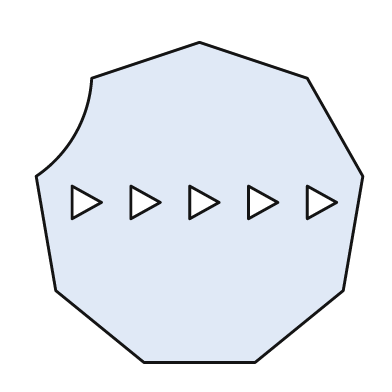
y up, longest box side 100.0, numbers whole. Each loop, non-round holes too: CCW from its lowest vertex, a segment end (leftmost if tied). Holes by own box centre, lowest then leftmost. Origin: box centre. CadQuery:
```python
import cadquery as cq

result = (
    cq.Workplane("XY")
    .moveTo(-17.0, -49.0)
    .lineTo(17.0, -49.0)
    .lineTo(44.0, -27.0)
    .lineTo(50.0, 8.0)
    .lineTo(33.0, 38.0)
    .lineTo(0.0, 49.0)
    .lineTo(-33.0, 38.0)
    .threePointArc((-38.0, 21.0), (-50.0, 8.0))
    .lineTo(-44.0, -27.0)
    .close()
    .moveTo(-39.0, -5.0)
    .lineTo(-30.0, 0.0)
    .lineTo(-39.0, 5.0)
    .close()
    .moveTo(-21.0, -5.0)
    .lineTo(-12.0, 0.0)
    .lineTo(-21.0, 5.0)
    .close()
    .moveTo(-3.0, -5.0)
    .lineTo(6.0, 0.0)
    .lineTo(-3.0, 5.0)
    .close()
    .moveTo(15.0, -5.0)
    .lineTo(24.0, 0.0)
    .lineTo(15.0, 5.0)
    .close()
    .moveTo(33.0, -5.0)
    .lineTo(42.0, 0.0)
    .lineTo(33.0, 5.0)
    .close()
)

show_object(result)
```